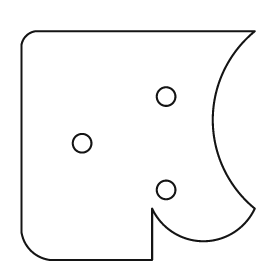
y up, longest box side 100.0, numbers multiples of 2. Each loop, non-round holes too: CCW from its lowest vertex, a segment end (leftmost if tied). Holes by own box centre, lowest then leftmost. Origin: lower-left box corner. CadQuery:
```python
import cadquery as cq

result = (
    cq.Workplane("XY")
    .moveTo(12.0, 0.0)
    .lineTo(56.0, 0.0)
    .lineTo(56.0, 22.0)
    .threePointArc((78.0, 8.0), (100.0, 22.0))
    .threePointArc((82.0, 60.0), (100.0, 98.0))
    .lineTo(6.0, 98.0)
    .threePointArc((2.0, 96.0), (0.0, 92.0))
    .lineTo(0.0, 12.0)
    .threePointArc((4.0, 4.0), (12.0, 0.0))
    .close()
    .moveTo(62.0, 30.0)
    .circle(4.0)
    .moveTo(26.0, 50.0)
    .circle(4.0)
    .moveTo(62.0, 70.0)
    .circle(4.0)
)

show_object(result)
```